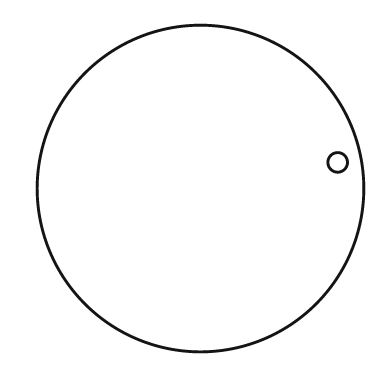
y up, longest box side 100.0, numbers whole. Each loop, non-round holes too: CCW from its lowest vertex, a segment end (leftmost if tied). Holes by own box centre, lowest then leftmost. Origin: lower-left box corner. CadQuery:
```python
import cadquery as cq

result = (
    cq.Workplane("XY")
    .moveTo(50.0, 50.0)
    .circle(50.0)
    .moveTo(92.0, 58.0)
    .circle(3.0)
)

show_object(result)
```